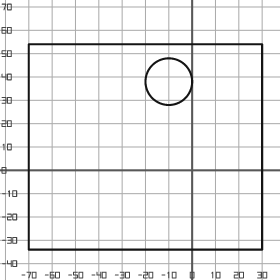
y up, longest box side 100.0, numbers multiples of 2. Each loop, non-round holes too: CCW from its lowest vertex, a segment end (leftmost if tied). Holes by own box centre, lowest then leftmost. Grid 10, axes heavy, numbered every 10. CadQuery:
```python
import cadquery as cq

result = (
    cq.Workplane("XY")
    .moveTo(-70.0, -34.0)
    .lineTo(30.0, -34.0)
    .lineTo(30.0, 54.0)
    .lineTo(-70.0, 54.0)
    .close()
    .moveTo(-10.0, 38.0)
    .circle(10.0)
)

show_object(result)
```